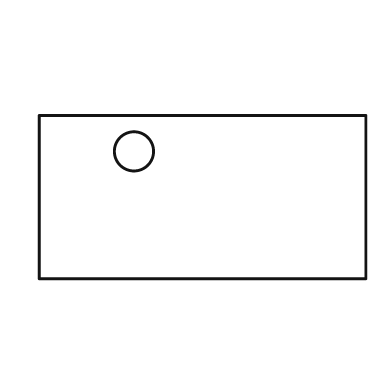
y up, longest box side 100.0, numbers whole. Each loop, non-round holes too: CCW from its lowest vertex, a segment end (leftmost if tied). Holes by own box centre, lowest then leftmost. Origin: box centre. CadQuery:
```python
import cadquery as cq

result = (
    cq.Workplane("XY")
    .moveTo(-50.0, -25.0)
    .lineTo(50.0, -25.0)
    .lineTo(50.0, 25.0)
    .lineTo(-50.0, 25.0)
    .close()
    .moveTo(-21.0, 14.0)
    .circle(6.0)
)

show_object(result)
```